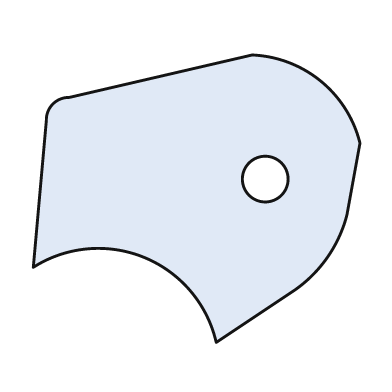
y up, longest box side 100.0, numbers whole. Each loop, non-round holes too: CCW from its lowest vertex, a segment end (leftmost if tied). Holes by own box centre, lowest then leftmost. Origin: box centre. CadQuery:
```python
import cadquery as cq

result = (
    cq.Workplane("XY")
    .moveTo(6.0, -44.0)
    .lineTo(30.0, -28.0)
    .threePointArc((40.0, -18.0), (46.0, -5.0))
    .lineTo(50.0, 17.0)
    .threePointArc((38.0, 36.0), (17.0, 44.0))
    .lineTo(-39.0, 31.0)
    .threePointArc((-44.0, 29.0), (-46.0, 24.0))
    .lineTo(-50.0, -21.0)
    .threePointArc((-16.0, -18.0), (6.0, -44.0))
    .close()
    .moveTo(21.0, 6.0)
    .circle(7.0)
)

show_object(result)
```